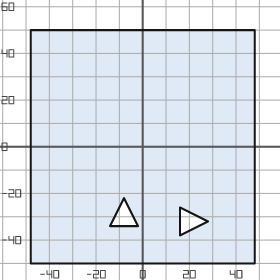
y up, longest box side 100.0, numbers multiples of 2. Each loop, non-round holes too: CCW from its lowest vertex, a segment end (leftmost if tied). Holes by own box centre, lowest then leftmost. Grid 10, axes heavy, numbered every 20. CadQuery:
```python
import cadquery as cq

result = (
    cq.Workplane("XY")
    .moveTo(-48.0, -50.0)
    .lineTo(48.0, -50.0)
    .lineTo(48.0, 50.0)
    .lineTo(-48.0, 50.0)
    .close()
    .moveTo(16.0, -38.0)
    .lineTo(28.0, -32.0)
    .lineTo(16.0, -26.0)
    .close()
    .moveTo(-14.0, -34.0)
    .lineTo(-2.0, -34.0)
    .lineTo(-8.0, -22.0)
    .close()
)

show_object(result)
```